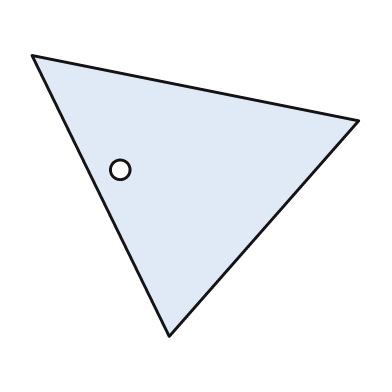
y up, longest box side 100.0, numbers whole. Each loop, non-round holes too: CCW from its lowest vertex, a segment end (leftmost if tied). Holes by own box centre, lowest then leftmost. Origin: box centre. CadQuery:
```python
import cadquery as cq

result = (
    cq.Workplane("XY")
    .moveTo(-8.0, -43.0)
    .lineTo(50.0, 23.0)
    .lineTo(-50.0, 43.0)
    .close()
    .moveTo(-23.0, 8.0)
    .circle(3.0)
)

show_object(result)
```